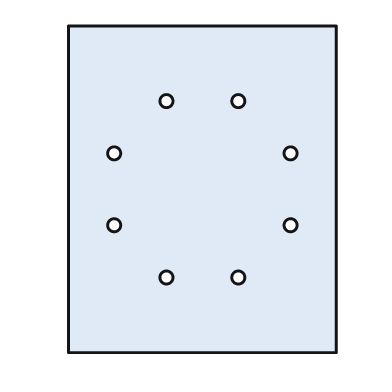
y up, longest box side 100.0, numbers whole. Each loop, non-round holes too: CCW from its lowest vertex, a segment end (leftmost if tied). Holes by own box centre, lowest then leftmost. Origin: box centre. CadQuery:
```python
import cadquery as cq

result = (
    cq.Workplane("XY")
    .moveTo(-41.0, -50.0)
    .lineTo(41.0, -50.0)
    .lineTo(41.0, 50.0)
    .lineTo(-41.0, 50.0)
    .close()
    .moveTo(-11.0, -27.0)
    .circle(2.0)
    .moveTo(11.0, -27.0)
    .circle(2.0)
    .moveTo(-27.0, -11.0)
    .circle(2.0)
    .moveTo(27.0, -11.0)
    .circle(2.0)
    .moveTo(-27.0, 11.0)
    .circle(2.0)
    .moveTo(27.0, 11.0)
    .circle(2.0)
    .moveTo(-11.0, 27.0)
    .circle(2.0)
    .moveTo(11.0, 27.0)
    .circle(2.0)
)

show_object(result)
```